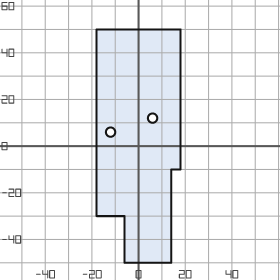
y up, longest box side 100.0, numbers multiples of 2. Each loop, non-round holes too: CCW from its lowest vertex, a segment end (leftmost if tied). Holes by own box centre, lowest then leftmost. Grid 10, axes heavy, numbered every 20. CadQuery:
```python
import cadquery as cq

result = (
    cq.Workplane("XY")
    .moveTo(-6.0, -50.0)
    .lineTo(14.0, -50.0)
    .lineTo(14.0, -10.0)
    .lineTo(18.0, -10.0)
    .lineTo(18.0, 50.0)
    .lineTo(-18.0, 50.0)
    .lineTo(-18.0, -30.0)
    .lineTo(-6.0, -30.0)
    .close()
    .moveTo(-12.0, 6.0)
    .circle(2.0)
    .moveTo(6.0, 12.0)
    .circle(2.0)
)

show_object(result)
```